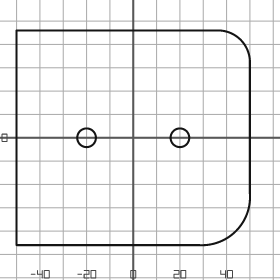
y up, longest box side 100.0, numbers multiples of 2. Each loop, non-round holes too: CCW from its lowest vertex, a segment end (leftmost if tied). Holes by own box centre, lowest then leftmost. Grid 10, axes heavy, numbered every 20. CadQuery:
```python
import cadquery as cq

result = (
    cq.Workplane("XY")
    .moveTo(-50.0, -46.0)
    .lineTo(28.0, -46.0)
    .threePointArc((44.0, -40.0), (50.0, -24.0))
    .lineTo(50.0, 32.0)
    .threePointArc((46.0, 42.0), (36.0, 46.0))
    .lineTo(-50.0, 46.0)
    .close()
    .moveTo(-20.0, 0.0)
    .circle(4.0)
    .moveTo(20.0, 0.0)
    .circle(4.0)
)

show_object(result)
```